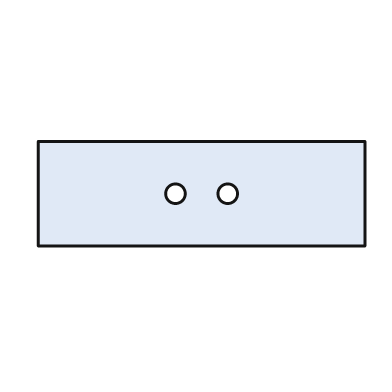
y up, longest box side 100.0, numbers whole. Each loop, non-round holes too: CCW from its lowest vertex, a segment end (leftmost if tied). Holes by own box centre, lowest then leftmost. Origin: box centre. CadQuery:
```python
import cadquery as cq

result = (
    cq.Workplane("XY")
    .moveTo(-50.0, -16.0)
    .lineTo(50.0, -16.0)
    .lineTo(50.0, 16.0)
    .lineTo(-50.0, 16.0)
    .close()
    .moveTo(-8.0, 0.0)
    .circle(3.0)
    .moveTo(8.0, 0.0)
    .circle(3.0)
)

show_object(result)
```